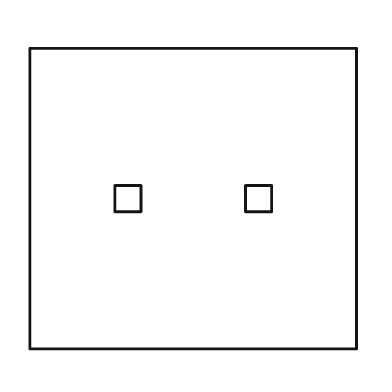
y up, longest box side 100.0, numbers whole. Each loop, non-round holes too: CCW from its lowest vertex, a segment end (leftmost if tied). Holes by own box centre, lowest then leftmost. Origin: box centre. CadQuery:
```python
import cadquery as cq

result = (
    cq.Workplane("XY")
    .moveTo(-50.0, -46.0)
    .lineTo(50.0, -46.0)
    .lineTo(50.0, 46.0)
    .lineTo(-50.0, 46.0)
    .close()
    .moveTo(-24.0, -4.0)
    .lineTo(-16.0, -4.0)
    .lineTo(-16.0, 4.0)
    .lineTo(-24.0, 4.0)
    .close()
    .moveTo(16.0, -4.0)
    .lineTo(24.0, -4.0)
    .lineTo(24.0, 4.0)
    .lineTo(16.0, 4.0)
    .close()
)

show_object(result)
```